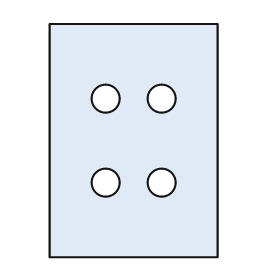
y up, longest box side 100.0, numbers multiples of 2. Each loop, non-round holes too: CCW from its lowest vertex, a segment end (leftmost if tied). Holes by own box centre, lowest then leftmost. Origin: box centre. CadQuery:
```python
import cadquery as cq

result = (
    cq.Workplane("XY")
    .moveTo(-36.0, -50.0)
    .lineTo(36.0, -50.0)
    .lineTo(36.0, 50.0)
    .lineTo(-36.0, 50.0)
    .close()
    .moveTo(-12.0, -18.0)
    .circle(6.0)
    .moveTo(12.0, -18.0)
    .circle(6.0)
    .moveTo(-12.0, 18.0)
    .circle(6.0)
    .moveTo(12.0, 18.0)
    .circle(6.0)
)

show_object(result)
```